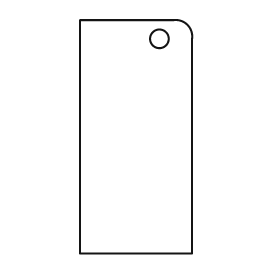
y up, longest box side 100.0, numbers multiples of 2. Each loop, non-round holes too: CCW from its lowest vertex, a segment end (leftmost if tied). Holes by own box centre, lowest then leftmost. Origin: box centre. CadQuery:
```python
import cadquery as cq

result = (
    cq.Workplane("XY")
    .moveTo(-24.0, -50.0)
    .lineTo(24.0, -50.0)
    .lineTo(24.0, 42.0)
    .threePointArc((22.0, 48.0), (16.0, 50.0))
    .lineTo(-24.0, 50.0)
    .close()
    .moveTo(10.0, 42.0)
    .circle(4.0)
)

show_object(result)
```